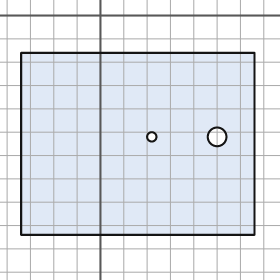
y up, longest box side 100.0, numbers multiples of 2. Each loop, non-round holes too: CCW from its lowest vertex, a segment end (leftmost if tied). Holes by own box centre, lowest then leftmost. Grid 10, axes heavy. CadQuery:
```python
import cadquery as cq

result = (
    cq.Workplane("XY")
    .moveTo(-34.0, -94.0)
    .lineTo(66.0, -94.0)
    .lineTo(66.0, -16.0)
    .lineTo(-34.0, -16.0)
    .close()
    .moveTo(22.0, -52.0)
    .circle(2.0)
    .moveTo(50.0, -52.0)
    .circle(4.0)
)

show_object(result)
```